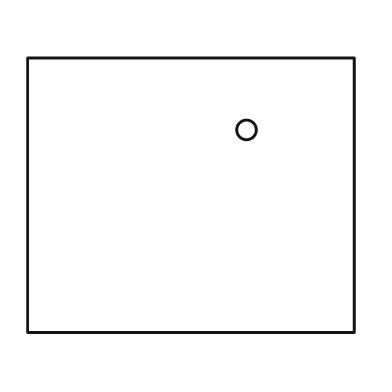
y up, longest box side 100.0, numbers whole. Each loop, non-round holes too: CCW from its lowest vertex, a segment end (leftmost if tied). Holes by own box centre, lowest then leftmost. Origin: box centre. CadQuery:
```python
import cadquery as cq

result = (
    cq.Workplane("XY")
    .moveTo(-50.0, -42.0)
    .lineTo(50.0, -42.0)
    .lineTo(50.0, 42.0)
    .lineTo(-50.0, 42.0)
    .close()
    .moveTo(17.0, 20.0)
    .circle(3.0)
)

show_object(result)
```